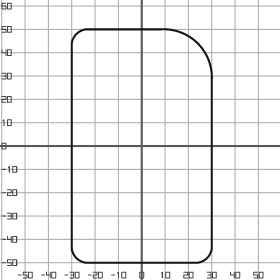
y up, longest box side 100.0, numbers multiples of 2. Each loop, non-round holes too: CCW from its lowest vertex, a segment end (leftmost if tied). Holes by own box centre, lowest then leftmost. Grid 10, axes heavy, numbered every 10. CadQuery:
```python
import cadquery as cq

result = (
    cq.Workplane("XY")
    .moveTo(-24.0, -50.0)
    .lineTo(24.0, -50.0)
    .threePointArc((28.0, -48.0), (30.0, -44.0))
    .lineTo(30.0, 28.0)
    .threePointArc((24.0, 44.0), (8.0, 50.0))
    .lineTo(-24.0, 50.0)
    .threePointArc((-28.0, 48.0), (-30.0, 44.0))
    .lineTo(-30.0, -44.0)
    .threePointArc((-28.0, -48.0), (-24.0, -50.0))
    .close()
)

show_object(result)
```